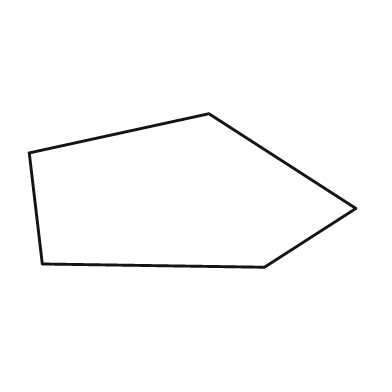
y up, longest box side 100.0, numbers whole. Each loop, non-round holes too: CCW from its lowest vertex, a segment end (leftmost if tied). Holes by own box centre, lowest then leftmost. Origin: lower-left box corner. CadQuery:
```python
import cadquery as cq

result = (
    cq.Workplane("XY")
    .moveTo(72.0, 0.0)
    .lineTo(100.0, 18.0)
    .lineTo(55.0, 47.0)
    .lineTo(0.0, 35.0)
    .lineTo(4.0, 1.0)
    .close()
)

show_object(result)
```